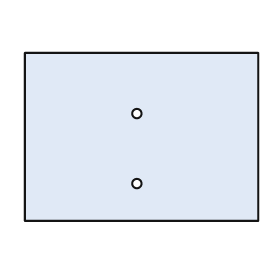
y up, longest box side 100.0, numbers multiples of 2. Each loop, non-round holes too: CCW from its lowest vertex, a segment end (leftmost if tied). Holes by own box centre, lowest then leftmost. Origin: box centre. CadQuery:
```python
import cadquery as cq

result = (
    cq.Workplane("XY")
    .moveTo(-50.0, -36.0)
    .lineTo(50.0, -36.0)
    .lineTo(50.0, 36.0)
    .lineTo(-50.0, 36.0)
    .close()
    .moveTo(-2.0, -20.0)
    .circle(2.0)
    .moveTo(-2.0, 10.0)
    .circle(2.0)
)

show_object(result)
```